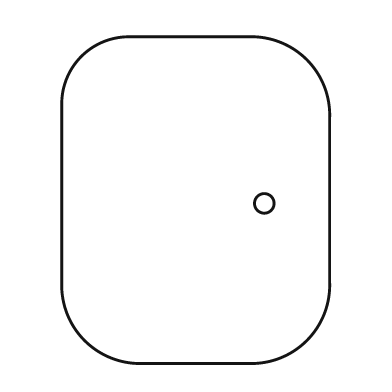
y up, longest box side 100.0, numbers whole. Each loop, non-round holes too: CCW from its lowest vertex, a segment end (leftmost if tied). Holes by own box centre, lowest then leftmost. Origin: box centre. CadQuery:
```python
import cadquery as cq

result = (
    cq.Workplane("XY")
    .moveTo(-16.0, -50.0)
    .lineTo(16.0, -50.0)
    .threePointArc((34.0, -43.0), (41.0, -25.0))
    .lineTo(41.0, 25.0)
    .threePointArc((34.0, 43.0), (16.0, 50.0))
    .lineTo(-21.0, 50.0)
    .threePointArc((-35.0, 44.0), (-41.0, 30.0))
    .lineTo(-41.0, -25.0)
    .threePointArc((-34.0, -43.0), (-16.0, -50.0))
    .close()
    .moveTo(21.0, -1.0)
    .circle(3.0)
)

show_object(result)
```